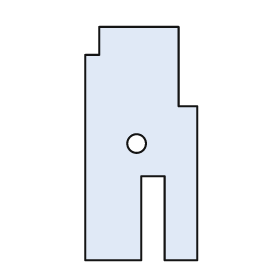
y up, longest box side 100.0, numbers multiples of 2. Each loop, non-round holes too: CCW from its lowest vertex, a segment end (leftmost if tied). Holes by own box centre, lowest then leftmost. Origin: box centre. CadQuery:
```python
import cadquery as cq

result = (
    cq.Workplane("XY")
    .moveTo(-24.0, -50.0)
    .lineTo(0.0, -50.0)
    .lineTo(0.0, -14.0)
    .lineTo(10.0, -14.0)
    .lineTo(10.0, -50.0)
    .lineTo(24.0, -50.0)
    .lineTo(24.0, 16.0)
    .lineTo(16.0, 16.0)
    .lineTo(16.0, 50.0)
    .lineTo(-18.0, 50.0)
    .lineTo(-18.0, 38.0)
    .lineTo(-24.0, 38.0)
    .close()
    .moveTo(-2.0, 0.0)
    .circle(4.0)
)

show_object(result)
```